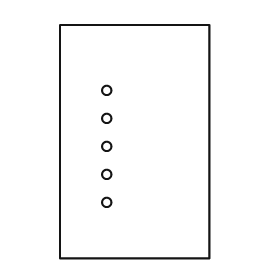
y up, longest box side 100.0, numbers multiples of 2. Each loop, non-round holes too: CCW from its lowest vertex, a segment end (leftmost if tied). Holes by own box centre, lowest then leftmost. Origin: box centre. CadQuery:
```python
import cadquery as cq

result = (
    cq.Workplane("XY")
    .moveTo(-32.0, -50.0)
    .lineTo(32.0, -50.0)
    .lineTo(32.0, 50.0)
    .lineTo(-32.0, 50.0)
    .close()
    .moveTo(-12.0, -26.0)
    .circle(2.0)
    .moveTo(-12.0, -14.0)
    .circle(2.0)
    .moveTo(-12.0, -2.0)
    .circle(2.0)
    .moveTo(-12.0, 10.0)
    .circle(2.0)
    .moveTo(-12.0, 22.0)
    .circle(2.0)
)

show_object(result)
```